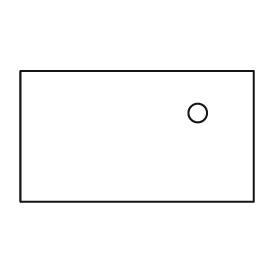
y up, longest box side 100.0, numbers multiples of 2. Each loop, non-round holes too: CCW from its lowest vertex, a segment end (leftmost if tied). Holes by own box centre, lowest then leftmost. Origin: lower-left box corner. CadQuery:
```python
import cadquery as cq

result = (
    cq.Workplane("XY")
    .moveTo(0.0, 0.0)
    .lineTo(100.0, 0.0)
    .lineTo(100.0, 56.0)
    .lineTo(0.0, 56.0)
    .close()
    .moveTo(76.0, 38.0)
    .circle(4.0)
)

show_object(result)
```